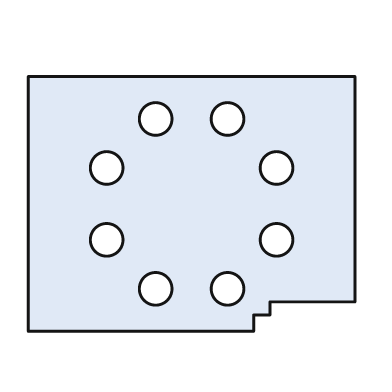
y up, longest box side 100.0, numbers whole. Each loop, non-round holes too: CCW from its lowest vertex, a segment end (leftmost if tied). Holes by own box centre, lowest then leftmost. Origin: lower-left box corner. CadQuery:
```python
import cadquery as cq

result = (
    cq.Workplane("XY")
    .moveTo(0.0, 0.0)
    .lineTo(69.0, 0.0)
    .lineTo(69.0, 5.0)
    .lineTo(74.0, 5.0)
    .lineTo(74.0, 9.0)
    .lineTo(100.0, 9.0)
    .lineTo(100.0, 78.0)
    .lineTo(0.0, 78.0)
    .close()
    .moveTo(39.0, 13.0)
    .circle(5.0)
    .moveTo(61.0, 13.0)
    .circle(5.0)
    .moveTo(24.0, 28.0)
    .circle(5.0)
    .moveTo(76.0, 28.0)
    .circle(5.0)
    .moveTo(24.0, 50.0)
    .circle(5.0)
    .moveTo(76.0, 50.0)
    .circle(5.0)
    .moveTo(39.0, 65.0)
    .circle(5.0)
    .moveTo(61.0, 65.0)
    .circle(5.0)
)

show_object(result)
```